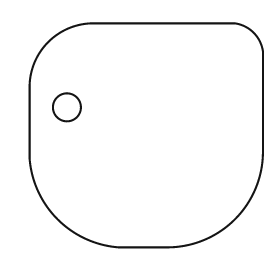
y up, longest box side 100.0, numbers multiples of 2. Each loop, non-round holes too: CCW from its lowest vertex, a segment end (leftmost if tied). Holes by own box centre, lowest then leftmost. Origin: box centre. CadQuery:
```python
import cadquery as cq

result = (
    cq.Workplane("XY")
    .moveTo(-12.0, -48.0)
    .lineTo(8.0, -48.0)
    .threePointArc((38.0, -36.0), (50.0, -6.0))
    .lineTo(50.0, 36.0)
    .threePointArc((46.0, 44.0), (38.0, 48.0))
    .lineTo(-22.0, 48.0)
    .threePointArc((-42.0, 40.0), (-50.0, 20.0))
    .lineTo(-50.0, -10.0)
    .threePointArc((-38.0, -36.0), (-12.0, -48.0))
    .close()
    .moveTo(-34.0, 12.0)
    .circle(6.0)
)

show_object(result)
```